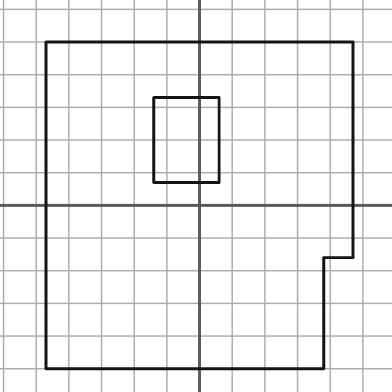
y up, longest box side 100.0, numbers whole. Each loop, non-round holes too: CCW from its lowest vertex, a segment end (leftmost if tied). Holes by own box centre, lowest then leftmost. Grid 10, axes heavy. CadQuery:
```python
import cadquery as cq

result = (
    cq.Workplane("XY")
    .moveTo(-47.0, -50.0)
    .lineTo(38.0, -50.0)
    .lineTo(38.0, -16.0)
    .lineTo(47.0, -16.0)
    .lineTo(47.0, 50.0)
    .lineTo(-47.0, 50.0)
    .close()
    .moveTo(-14.0, 7.0)
    .lineTo(6.0, 7.0)
    .lineTo(6.0, 33.0)
    .lineTo(-14.0, 33.0)
    .close()
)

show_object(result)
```